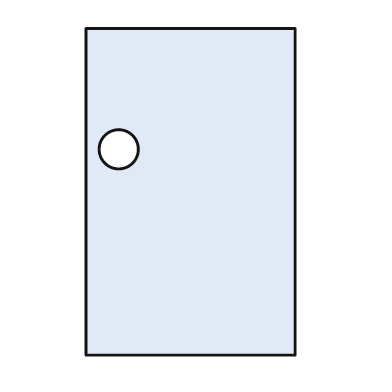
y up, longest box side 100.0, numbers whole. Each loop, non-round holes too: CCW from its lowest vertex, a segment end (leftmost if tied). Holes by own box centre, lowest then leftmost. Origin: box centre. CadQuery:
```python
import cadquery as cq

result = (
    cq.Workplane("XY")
    .moveTo(-32.0, -50.0)
    .lineTo(32.0, -50.0)
    .lineTo(32.0, 50.0)
    .lineTo(-32.0, 50.0)
    .close()
    .moveTo(-22.0, 13.0)
    .circle(6.0)
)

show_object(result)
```